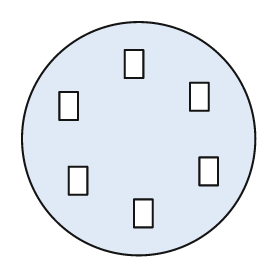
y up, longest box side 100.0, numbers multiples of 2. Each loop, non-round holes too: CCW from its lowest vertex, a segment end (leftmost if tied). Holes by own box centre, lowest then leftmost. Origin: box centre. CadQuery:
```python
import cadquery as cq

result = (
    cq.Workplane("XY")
    .moveTo(0.0, 0.0)
    .circle(50.0)
    .moveTo(-2.0, -38.0)
    .lineTo(6.0, -38.0)
    .lineTo(6.0, -26.0)
    .lineTo(-2.0, -26.0)
    .close()
    .moveTo(-30.0, -24.0)
    .lineTo(-22.0, -24.0)
    .lineTo(-22.0, -12.0)
    .lineTo(-30.0, -12.0)
    .close()
    .moveTo(26.0, -20.0)
    .lineTo(34.0, -20.0)
    .lineTo(34.0, -8.0)
    .lineTo(26.0, -8.0)
    .close()
    .moveTo(-34.0, 8.0)
    .lineTo(-26.0, 8.0)
    .lineTo(-26.0, 20.0)
    .lineTo(-34.0, 20.0)
    .close()
    .moveTo(22.0, 12.0)
    .lineTo(30.0, 12.0)
    .lineTo(30.0, 24.0)
    .lineTo(22.0, 24.0)
    .close()
    .moveTo(-6.0, 26.0)
    .lineTo(2.0, 26.0)
    .lineTo(2.0, 38.0)
    .lineTo(-6.0, 38.0)
    .close()
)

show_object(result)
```